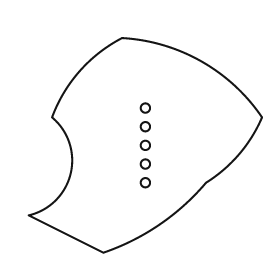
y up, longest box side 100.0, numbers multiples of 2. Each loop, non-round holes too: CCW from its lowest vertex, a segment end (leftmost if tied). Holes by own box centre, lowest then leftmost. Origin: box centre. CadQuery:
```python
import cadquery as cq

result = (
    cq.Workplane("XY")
    .moveTo(-18.0, -46.0)
    .threePointArc((6.0, -34.0), (26.0, -16.0))
    .threePointArc((40.0, -4.0), (50.0, 12.0))
    .threePointArc((24.0, 36.0), (-10.0, 46.0))
    .threePointArc((-28.0, 32.0), (-40.0, 12.0))
    .threePointArc((-32.0, -12.0), (-50.0, -30.0))
    .close()
    .moveTo(0.0, -16.0)
    .circle(2.0)
    .moveTo(0.0, -8.0)
    .circle(2.0)
    .moveTo(0.0, 0.0)
    .circle(2.0)
    .moveTo(0.0, 8.0)
    .circle(2.0)
    .moveTo(0.0, 16.0)
    .circle(2.0)
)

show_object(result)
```